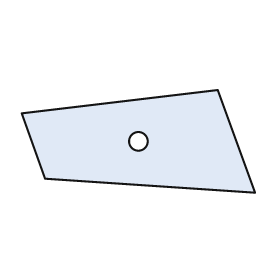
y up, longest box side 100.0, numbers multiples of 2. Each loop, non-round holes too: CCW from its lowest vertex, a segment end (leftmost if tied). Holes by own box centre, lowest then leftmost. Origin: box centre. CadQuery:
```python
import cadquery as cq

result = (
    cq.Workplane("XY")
    .moveTo(50.0, -22.0)
    .lineTo(34.0, 22.0)
    .lineTo(-50.0, 12.0)
    .lineTo(-40.0, -16.0)
    .close()
    .moveTo(0.0, 0.0)
    .circle(4.0)
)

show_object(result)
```